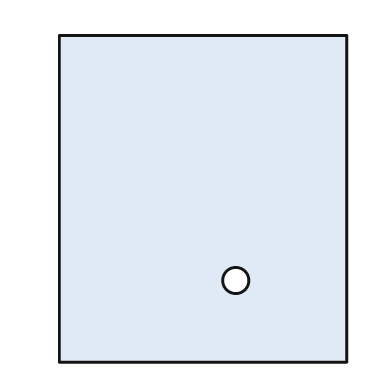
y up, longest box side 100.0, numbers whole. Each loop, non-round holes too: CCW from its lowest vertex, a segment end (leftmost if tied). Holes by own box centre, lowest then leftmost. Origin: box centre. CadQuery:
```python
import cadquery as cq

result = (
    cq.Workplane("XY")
    .moveTo(-44.0, -50.0)
    .lineTo(44.0, -50.0)
    .lineTo(44.0, 50.0)
    .lineTo(-44.0, 50.0)
    .close()
    .moveTo(10.0, -25.0)
    .circle(4.0)
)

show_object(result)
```